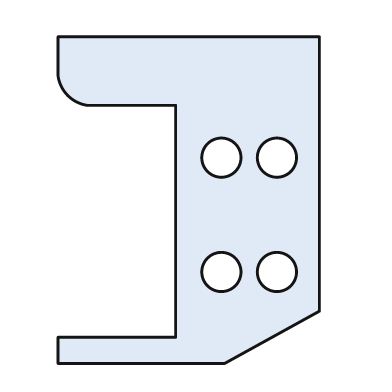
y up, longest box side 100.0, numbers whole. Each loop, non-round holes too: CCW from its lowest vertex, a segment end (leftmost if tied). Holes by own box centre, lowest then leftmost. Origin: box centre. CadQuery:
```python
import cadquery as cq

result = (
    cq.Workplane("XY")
    .moveTo(-40.0, -50.0)
    .lineTo(11.0, -50.0)
    .lineTo(40.0, -34.0)
    .lineTo(40.0, 50.0)
    .lineTo(-40.0, 50.0)
    .lineTo(-40.0, 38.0)
    .threePointArc((-37.0, 32.0), (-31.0, 29.0))
    .lineTo(-4.0, 29.0)
    .lineTo(-4.0, -42.0)
    .lineTo(-40.0, -42.0)
    .close()
    .moveTo(10.0, -22.0)
    .circle(6.0)
    .moveTo(27.0, -22.0)
    .circle(6.0)
    .moveTo(10.0, 13.0)
    .circle(6.0)
    .moveTo(27.0, 13.0)
    .circle(6.0)
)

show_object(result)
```